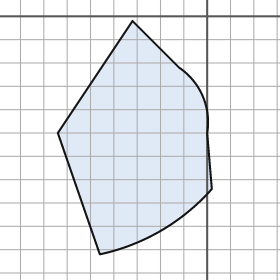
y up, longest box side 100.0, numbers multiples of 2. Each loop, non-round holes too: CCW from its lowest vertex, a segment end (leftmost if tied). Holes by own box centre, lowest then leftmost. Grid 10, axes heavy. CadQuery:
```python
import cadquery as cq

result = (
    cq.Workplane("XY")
    .moveTo(-46.0, -102.0)
    .threePointArc((-20.0, -92.0), (2.0, -74.0))
    .lineTo(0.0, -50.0)
    .threePointArc((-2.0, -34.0), (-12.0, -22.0))
    .lineTo(-32.0, -2.0)
    .lineTo(-64.0, -50.0)
    .close()
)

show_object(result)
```